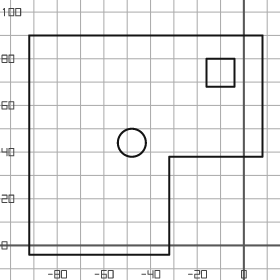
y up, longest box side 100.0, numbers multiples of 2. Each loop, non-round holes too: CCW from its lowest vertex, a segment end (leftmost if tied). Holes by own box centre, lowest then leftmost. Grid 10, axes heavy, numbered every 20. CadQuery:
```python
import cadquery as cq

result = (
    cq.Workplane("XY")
    .moveTo(-92.0, -4.0)
    .lineTo(-32.0, -4.0)
    .lineTo(-32.0, 38.0)
    .lineTo(8.0, 38.0)
    .lineTo(8.0, 90.0)
    .lineTo(-92.0, 90.0)
    .close()
    .moveTo(-48.0, 44.0)
    .circle(6.0)
    .moveTo(-16.0, 68.0)
    .lineTo(-4.0, 68.0)
    .lineTo(-4.0, 80.0)
    .lineTo(-16.0, 80.0)
    .close()
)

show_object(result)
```